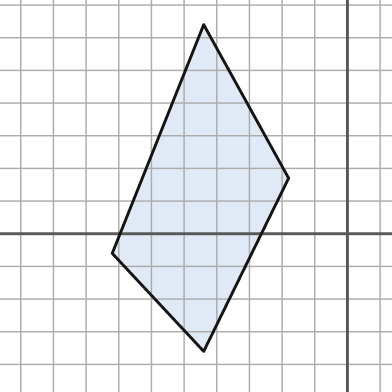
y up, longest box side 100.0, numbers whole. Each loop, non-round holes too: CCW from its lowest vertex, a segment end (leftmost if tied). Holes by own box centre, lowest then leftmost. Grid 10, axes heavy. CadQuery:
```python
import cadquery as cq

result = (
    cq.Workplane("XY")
    .moveTo(-44.0, -36.0)
    .lineTo(-18.0, 17.0)
    .lineTo(-44.0, 64.0)
    .lineTo(-72.0, -6.0)
    .close()
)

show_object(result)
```